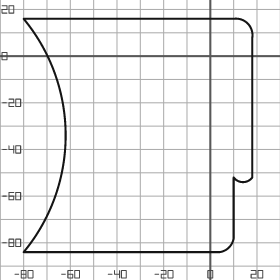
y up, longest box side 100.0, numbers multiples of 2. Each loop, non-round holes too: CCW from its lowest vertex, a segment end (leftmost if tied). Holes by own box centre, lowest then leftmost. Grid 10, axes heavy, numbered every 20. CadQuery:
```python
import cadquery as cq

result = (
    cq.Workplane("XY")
    .moveTo(-80.0, -84.0)
    .lineTo(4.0, -84.0)
    .threePointArc((8.0, -82.0), (10.0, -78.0))
    .lineTo(10.0, -52.0)
    .threePointArc((14.0, -54.0), (18.0, -52.0))
    .lineTo(18.0, 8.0)
    .threePointArc((16.0, 14.0), (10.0, 16.0))
    .lineTo(-80.0, 16.0)
    .threePointArc((-62.0, -34.0), (-80.0, -84.0))
    .close()
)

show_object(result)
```